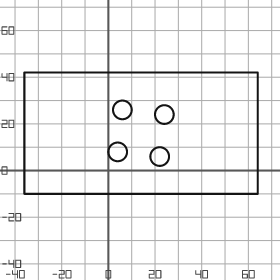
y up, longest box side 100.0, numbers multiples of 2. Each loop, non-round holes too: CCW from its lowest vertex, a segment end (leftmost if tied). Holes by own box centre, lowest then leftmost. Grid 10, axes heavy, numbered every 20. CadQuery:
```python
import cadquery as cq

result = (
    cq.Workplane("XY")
    .moveTo(-36.0, -10.0)
    .lineTo(64.0, -10.0)
    .lineTo(64.0, 42.0)
    .lineTo(-36.0, 42.0)
    .close()
    .moveTo(22.0, 6.0)
    .circle(4.0)
    .moveTo(4.0, 8.0)
    .circle(4.0)
    .moveTo(24.0, 24.0)
    .circle(4.0)
    .moveTo(6.0, 26.0)
    .circle(4.0)
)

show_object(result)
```